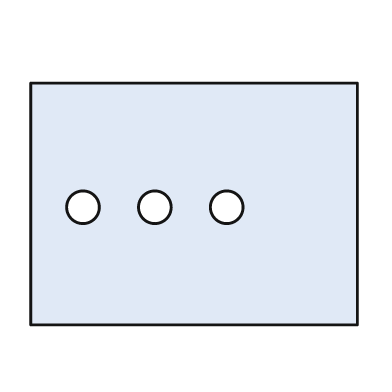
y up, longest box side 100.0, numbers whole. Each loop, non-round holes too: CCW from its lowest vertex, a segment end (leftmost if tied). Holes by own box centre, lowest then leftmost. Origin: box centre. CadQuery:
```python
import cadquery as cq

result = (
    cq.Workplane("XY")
    .moveTo(-50.0, -37.0)
    .lineTo(50.0, -37.0)
    .lineTo(50.0, 37.0)
    .lineTo(-50.0, 37.0)
    .close()
    .moveTo(-34.0, -1.0)
    .circle(5.0)
    .moveTo(-12.0, -1.0)
    .circle(5.0)
    .moveTo(10.0, -1.0)
    .circle(5.0)
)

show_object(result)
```